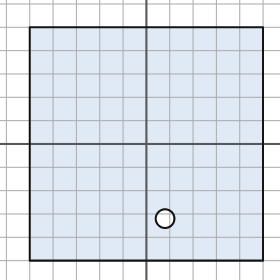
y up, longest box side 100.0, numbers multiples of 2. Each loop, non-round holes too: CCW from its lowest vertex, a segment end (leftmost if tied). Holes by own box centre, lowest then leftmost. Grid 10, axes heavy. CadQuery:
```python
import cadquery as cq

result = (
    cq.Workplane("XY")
    .moveTo(-50.0, -50.0)
    .lineTo(50.0, -50.0)
    .lineTo(50.0, 50.0)
    .lineTo(-50.0, 50.0)
    .close()
    .moveTo(8.0, -32.0)
    .circle(4.0)
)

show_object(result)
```